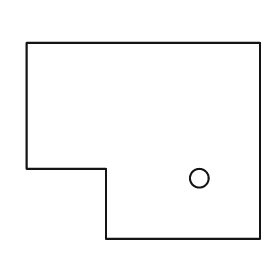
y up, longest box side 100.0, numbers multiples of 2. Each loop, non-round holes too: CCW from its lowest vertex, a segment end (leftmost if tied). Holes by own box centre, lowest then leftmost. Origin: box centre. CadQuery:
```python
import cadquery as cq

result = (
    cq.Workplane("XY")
    .moveTo(-16.0, -42.0)
    .lineTo(50.0, -42.0)
    .lineTo(50.0, 42.0)
    .lineTo(-50.0, 42.0)
    .lineTo(-50.0, -12.0)
    .lineTo(-16.0, -12.0)
    .close()
    .moveTo(24.0, -16.0)
    .circle(4.0)
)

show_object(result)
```